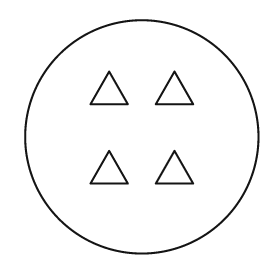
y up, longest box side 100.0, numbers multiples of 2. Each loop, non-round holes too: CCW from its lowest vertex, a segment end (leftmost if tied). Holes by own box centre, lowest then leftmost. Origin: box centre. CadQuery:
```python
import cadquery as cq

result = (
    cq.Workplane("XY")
    .moveTo(0.0, 0.0)
    .circle(50.0)
    .moveTo(-22.0, -20.0)
    .lineTo(-6.0, -20.0)
    .lineTo(-14.0, -6.0)
    .close()
    .moveTo(6.0, -20.0)
    .lineTo(22.0, -20.0)
    .lineTo(14.0, -6.0)
    .close()
    .moveTo(-22.0, 14.0)
    .lineTo(-6.0, 14.0)
    .lineTo(-14.0, 28.0)
    .close()
    .moveTo(6.0, 14.0)
    .lineTo(22.0, 14.0)
    .lineTo(14.0, 28.0)
    .close()
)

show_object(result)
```